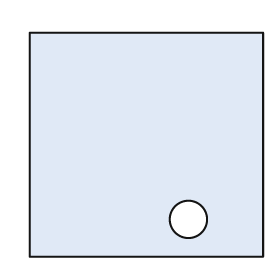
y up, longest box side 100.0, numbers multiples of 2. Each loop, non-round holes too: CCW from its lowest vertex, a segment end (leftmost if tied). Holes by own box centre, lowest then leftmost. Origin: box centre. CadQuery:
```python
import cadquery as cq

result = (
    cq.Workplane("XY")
    .moveTo(-50.0, -48.0)
    .lineTo(50.0, -48.0)
    .lineTo(50.0, 48.0)
    .lineTo(-50.0, 48.0)
    .close()
    .moveTo(18.0, -32.0)
    .circle(8.0)
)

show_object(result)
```